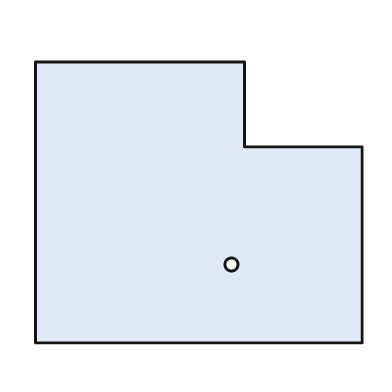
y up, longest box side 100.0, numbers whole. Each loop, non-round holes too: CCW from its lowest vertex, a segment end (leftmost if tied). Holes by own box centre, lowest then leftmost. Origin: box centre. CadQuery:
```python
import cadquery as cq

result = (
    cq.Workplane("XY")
    .moveTo(-50.0, -43.0)
    .lineTo(50.0, -43.0)
    .lineTo(50.0, 17.0)
    .lineTo(14.0, 17.0)
    .lineTo(14.0, 43.0)
    .lineTo(-50.0, 43.0)
    .close()
    .moveTo(10.0, -19.0)
    .circle(2.0)
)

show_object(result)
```